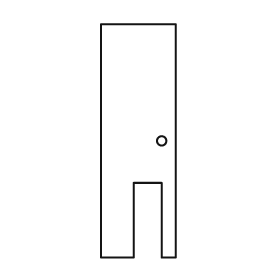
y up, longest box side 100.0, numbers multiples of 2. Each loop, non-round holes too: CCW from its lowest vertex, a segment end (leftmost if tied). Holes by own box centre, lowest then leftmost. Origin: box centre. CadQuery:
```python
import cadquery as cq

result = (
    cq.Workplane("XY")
    .moveTo(-16.0, -50.0)
    .lineTo(-2.0, -50.0)
    .lineTo(-2.0, -18.0)
    .lineTo(10.0, -18.0)
    .lineTo(10.0, -50.0)
    .lineTo(16.0, -50.0)
    .lineTo(16.0, 50.0)
    .lineTo(-16.0, 50.0)
    .close()
    .moveTo(10.0, 0.0)
    .circle(2.0)
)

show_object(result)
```